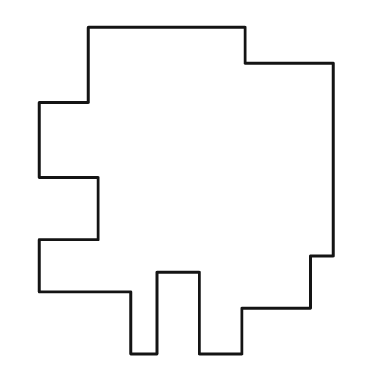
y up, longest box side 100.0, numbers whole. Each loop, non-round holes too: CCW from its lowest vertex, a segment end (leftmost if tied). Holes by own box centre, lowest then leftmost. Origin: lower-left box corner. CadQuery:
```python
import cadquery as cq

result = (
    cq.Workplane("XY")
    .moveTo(28.0, 0.0)
    .lineTo(36.0, 0.0)
    .lineTo(36.0, 25.0)
    .lineTo(49.0, 25.0)
    .lineTo(49.0, 0.0)
    .lineTo(62.0, 0.0)
    .lineTo(62.0, 14.0)
    .lineTo(83.0, 14.0)
    .lineTo(83.0, 30.0)
    .lineTo(90.0, 30.0)
    .lineTo(90.0, 89.0)
    .lineTo(63.0, 89.0)
    .lineTo(63.0, 100.0)
    .lineTo(15.0, 100.0)
    .lineTo(15.0, 77.0)
    .lineTo(0.0, 77.0)
    .lineTo(0.0, 54.0)
    .lineTo(18.0, 54.0)
    .lineTo(18.0, 35.0)
    .lineTo(0.0, 35.0)
    .lineTo(0.0, 19.0)
    .lineTo(28.0, 19.0)
    .close()
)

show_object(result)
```